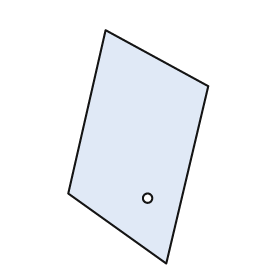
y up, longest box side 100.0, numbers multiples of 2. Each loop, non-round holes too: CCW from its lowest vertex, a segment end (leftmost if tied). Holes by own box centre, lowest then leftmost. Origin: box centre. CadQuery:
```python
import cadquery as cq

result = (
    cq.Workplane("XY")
    .moveTo(12.0, -50.0)
    .lineTo(30.0, 26.0)
    .lineTo(-14.0, 50.0)
    .lineTo(-30.0, -20.0)
    .close()
    .moveTo(4.0, -22.0)
    .circle(2.0)
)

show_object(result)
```